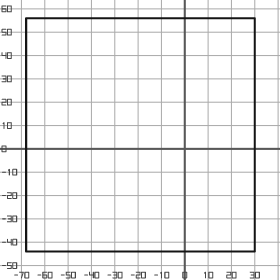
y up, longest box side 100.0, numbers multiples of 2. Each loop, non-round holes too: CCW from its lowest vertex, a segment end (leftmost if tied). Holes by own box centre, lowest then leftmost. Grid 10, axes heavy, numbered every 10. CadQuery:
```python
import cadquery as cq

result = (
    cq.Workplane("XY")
    .moveTo(-68.0, -44.0)
    .lineTo(30.0, -44.0)
    .lineTo(30.0, 56.0)
    .lineTo(-68.0, 56.0)
    .close()
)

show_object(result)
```